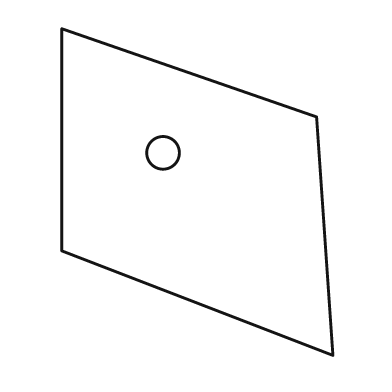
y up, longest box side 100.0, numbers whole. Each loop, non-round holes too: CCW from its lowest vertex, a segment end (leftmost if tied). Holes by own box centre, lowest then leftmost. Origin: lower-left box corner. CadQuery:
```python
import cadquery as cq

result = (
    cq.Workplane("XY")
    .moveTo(83.0, 0.0)
    .lineTo(78.0, 73.0)
    .lineTo(0.0, 100.0)
    .lineTo(0.0, 32.0)
    .close()
    .moveTo(31.0, 62.0)
    .circle(5.0)
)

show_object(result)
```